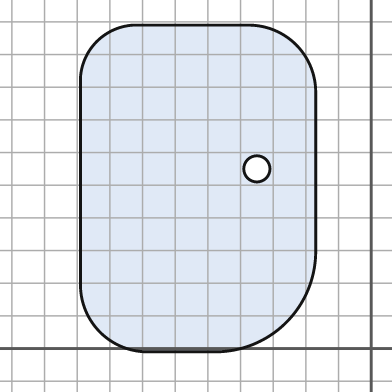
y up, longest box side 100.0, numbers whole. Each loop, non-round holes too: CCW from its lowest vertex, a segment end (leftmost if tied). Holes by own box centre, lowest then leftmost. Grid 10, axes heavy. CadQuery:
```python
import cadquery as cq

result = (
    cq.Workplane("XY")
    .moveTo(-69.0, -1.0)
    .lineTo(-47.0, -1.0)
    .threePointArc((-26.0, 8.0), (-17.0, 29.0))
    .lineTo(-17.0, 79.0)
    .threePointArc((-23.0, 93.0), (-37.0, 99.0))
    .lineTo(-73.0, 99.0)
    .threePointArc((-84.0, 94.0), (-89.0, 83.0))
    .lineTo(-89.0, 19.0)
    .threePointArc((-83.0, 5.0), (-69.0, -1.0))
    .close()
    .moveTo(-35.0, 55.0)
    .circle(4.0)
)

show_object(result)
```